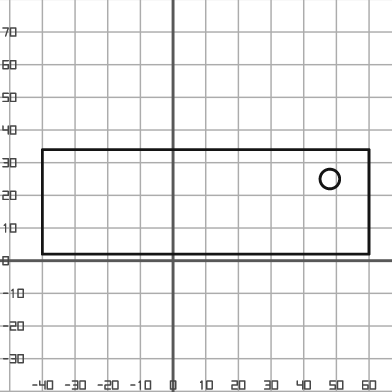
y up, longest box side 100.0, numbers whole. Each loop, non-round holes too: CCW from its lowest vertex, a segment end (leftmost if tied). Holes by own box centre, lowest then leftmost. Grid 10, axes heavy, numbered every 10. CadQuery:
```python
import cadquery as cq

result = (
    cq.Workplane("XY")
    .moveTo(-40.0, 2.0)
    .lineTo(60.0, 2.0)
    .lineTo(60.0, 34.0)
    .lineTo(-40.0, 34.0)
    .close()
    .moveTo(48.0, 25.0)
    .circle(3.0)
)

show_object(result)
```